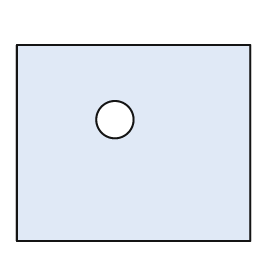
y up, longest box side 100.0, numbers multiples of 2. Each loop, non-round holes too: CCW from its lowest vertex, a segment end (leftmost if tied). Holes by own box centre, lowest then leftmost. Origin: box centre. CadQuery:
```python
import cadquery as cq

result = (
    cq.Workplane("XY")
    .moveTo(-50.0, -42.0)
    .lineTo(50.0, -42.0)
    .lineTo(50.0, 42.0)
    .lineTo(-50.0, 42.0)
    .close()
    .moveTo(-8.0, 10.0)
    .circle(8.0)
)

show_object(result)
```